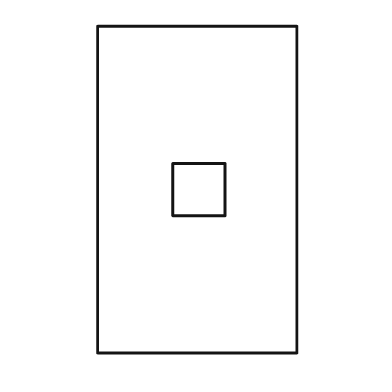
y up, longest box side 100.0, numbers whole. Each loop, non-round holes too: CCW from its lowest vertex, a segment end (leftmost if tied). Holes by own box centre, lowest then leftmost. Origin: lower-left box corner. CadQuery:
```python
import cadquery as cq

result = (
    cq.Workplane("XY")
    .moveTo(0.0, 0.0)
    .lineTo(61.0, 0.0)
    .lineTo(61.0, 100.0)
    .lineTo(0.0, 100.0)
    .close()
    .moveTo(23.0, 42.0)
    .lineTo(39.0, 42.0)
    .lineTo(39.0, 58.0)
    .lineTo(23.0, 58.0)
    .close()
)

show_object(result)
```